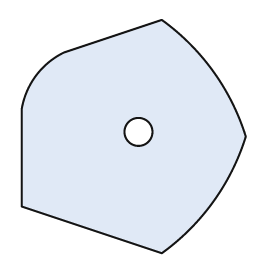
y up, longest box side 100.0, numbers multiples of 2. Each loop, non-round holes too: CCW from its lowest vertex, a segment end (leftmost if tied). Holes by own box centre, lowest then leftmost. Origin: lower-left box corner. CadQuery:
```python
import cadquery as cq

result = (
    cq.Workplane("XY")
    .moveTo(60.0, 0.0)
    .threePointArc((82.0, 22.0), (96.0, 50.0))
    .threePointArc((82.0, 78.0), (60.0, 100.0))
    .lineTo(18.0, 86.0)
    .threePointArc((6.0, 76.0), (0.0, 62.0))
    .lineTo(0.0, 20.0)
    .close()
    .moveTo(50.0, 52.0)
    .circle(6.0)
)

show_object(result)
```